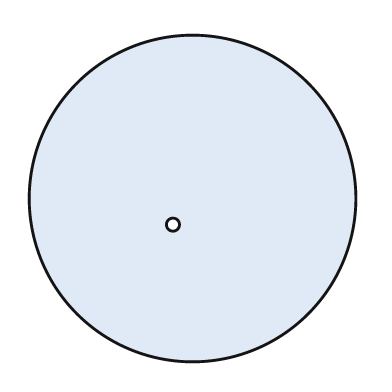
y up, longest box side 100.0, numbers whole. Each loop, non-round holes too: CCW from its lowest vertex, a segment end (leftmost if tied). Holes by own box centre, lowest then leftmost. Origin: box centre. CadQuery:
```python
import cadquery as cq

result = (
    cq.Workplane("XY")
    .moveTo(0.0, 0.0)
    .circle(50.0)
    .moveTo(-6.0, -8.0)
    .circle(2.0)
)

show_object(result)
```